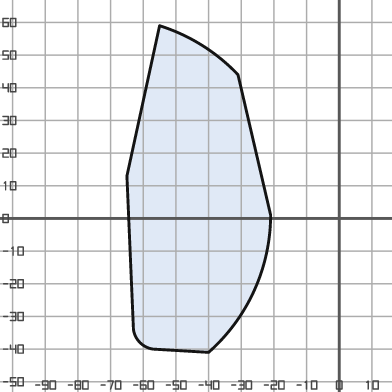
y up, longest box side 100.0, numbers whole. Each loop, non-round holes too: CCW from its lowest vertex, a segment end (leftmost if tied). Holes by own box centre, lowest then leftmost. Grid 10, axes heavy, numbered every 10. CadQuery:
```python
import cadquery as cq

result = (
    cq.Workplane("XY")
    .moveTo(-40.0, -41.0)
    .threePointArc((-26.0, -22.0), (-21.0, 1.0))
    .lineTo(-31.0, 44.0)
    .threePointArc((-42.0, 53.0), (-55.0, 59.0))
    .lineTo(-65.0, 13.0)
    .lineTo(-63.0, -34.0)
    .threePointArc((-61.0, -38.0), (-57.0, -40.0))
    .close()
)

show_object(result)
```